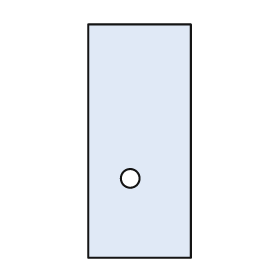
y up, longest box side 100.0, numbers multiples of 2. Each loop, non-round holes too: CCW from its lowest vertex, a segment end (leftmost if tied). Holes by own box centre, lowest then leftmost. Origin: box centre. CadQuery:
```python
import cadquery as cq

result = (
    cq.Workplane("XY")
    .moveTo(-22.0, -50.0)
    .lineTo(22.0, -50.0)
    .lineTo(22.0, 50.0)
    .lineTo(-22.0, 50.0)
    .close()
    .moveTo(-4.0, -16.0)
    .circle(4.0)
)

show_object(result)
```